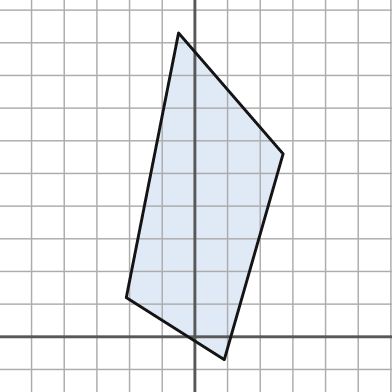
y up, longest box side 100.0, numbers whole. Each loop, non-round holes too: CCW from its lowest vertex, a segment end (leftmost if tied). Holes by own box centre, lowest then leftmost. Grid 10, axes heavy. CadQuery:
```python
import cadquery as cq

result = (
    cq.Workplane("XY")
    .moveTo(9.0, -7.0)
    .lineTo(27.0, 56.0)
    .lineTo(-5.0, 93.0)
    .lineTo(-21.0, 12.0)
    .close()
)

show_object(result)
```